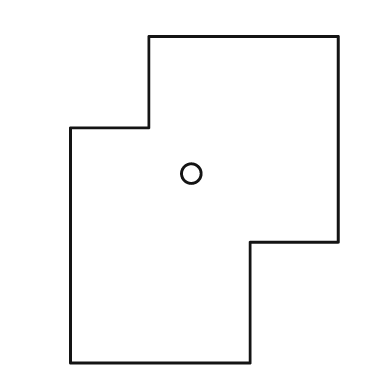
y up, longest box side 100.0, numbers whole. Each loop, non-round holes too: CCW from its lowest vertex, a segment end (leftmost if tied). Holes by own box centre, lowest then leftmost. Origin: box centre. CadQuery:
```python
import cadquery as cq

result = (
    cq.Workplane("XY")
    .moveTo(-41.0, -50.0)
    .lineTo(14.0, -50.0)
    .lineTo(14.0, -13.0)
    .lineTo(41.0, -13.0)
    .lineTo(41.0, 50.0)
    .lineTo(-17.0, 50.0)
    .lineTo(-17.0, 22.0)
    .lineTo(-41.0, 22.0)
    .close()
    .moveTo(-4.0, 8.0)
    .circle(3.0)
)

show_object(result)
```